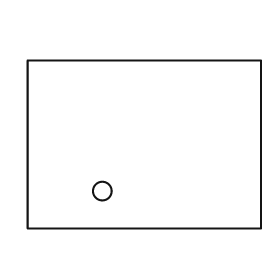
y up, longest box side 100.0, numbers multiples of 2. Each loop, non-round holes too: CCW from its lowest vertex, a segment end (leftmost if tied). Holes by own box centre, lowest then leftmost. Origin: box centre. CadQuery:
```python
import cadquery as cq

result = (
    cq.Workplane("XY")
    .moveTo(-50.0, -36.0)
    .lineTo(50.0, -36.0)
    .lineTo(50.0, 36.0)
    .lineTo(-50.0, 36.0)
    .close()
    .moveTo(-18.0, -20.0)
    .circle(4.0)
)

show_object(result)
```